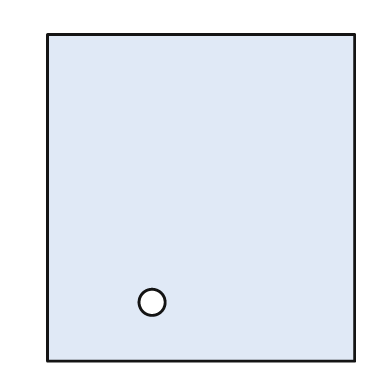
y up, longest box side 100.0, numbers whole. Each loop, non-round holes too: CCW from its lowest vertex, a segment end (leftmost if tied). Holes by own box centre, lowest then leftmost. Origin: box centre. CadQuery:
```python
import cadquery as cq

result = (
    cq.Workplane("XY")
    .moveTo(-47.0, -50.0)
    .lineTo(47.0, -50.0)
    .lineTo(47.0, 50.0)
    .lineTo(-47.0, 50.0)
    .close()
    .moveTo(-15.0, -32.0)
    .circle(4.0)
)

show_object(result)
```